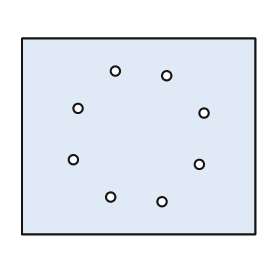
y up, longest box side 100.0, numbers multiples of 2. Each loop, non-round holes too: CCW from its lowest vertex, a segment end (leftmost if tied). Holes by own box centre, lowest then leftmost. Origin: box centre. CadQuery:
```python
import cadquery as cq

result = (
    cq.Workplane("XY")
    .moveTo(-50.0, -42.0)
    .lineTo(50.0, -42.0)
    .lineTo(50.0, 42.0)
    .lineTo(-50.0, 42.0)
    .close()
    .moveTo(10.0, -28.0)
    .circle(2.0)
    .moveTo(-12.0, -26.0)
    .circle(2.0)
    .moveTo(26.0, -12.0)
    .circle(2.0)
    .moveTo(-28.0, -10.0)
    .circle(2.0)
    .moveTo(28.0, 10.0)
    .circle(2.0)
    .moveTo(-26.0, 12.0)
    .circle(2.0)
    .moveTo(12.0, 26.0)
    .circle(2.0)
    .moveTo(-10.0, 28.0)
    .circle(2.0)
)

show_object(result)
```